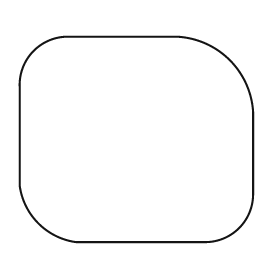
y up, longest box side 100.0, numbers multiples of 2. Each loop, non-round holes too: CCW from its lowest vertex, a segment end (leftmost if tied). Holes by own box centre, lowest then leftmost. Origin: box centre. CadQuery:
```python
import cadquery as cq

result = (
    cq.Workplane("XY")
    .moveTo(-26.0, -44.0)
    .lineTo(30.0, -44.0)
    .threePointArc((44.0, -38.0), (50.0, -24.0))
    .lineTo(50.0, 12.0)
    .threePointArc((40.0, 34.0), (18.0, 44.0))
    .lineTo(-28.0, 44.0)
    .threePointArc((-44.0, 38.0), (-50.0, 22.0))
    .lineTo(-50.0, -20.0)
    .threePointArc((-42.0, -36.0), (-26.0, -44.0))
    .close()
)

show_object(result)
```